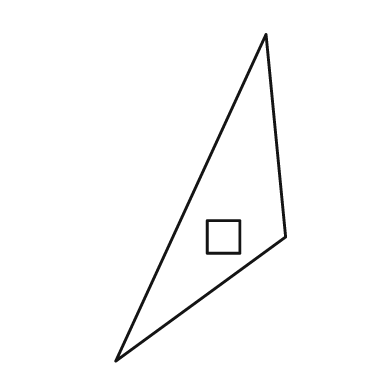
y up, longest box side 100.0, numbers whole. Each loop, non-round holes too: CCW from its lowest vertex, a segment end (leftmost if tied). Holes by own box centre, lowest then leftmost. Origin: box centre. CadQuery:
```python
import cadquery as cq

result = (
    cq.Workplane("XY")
    .moveTo(-26.0, -50.0)
    .lineTo(26.0, -12.0)
    .lineTo(20.0, 50.0)
    .close()
    .moveTo(2.0, -17.0)
    .lineTo(12.0, -17.0)
    .lineTo(12.0, -7.0)
    .lineTo(2.0, -7.0)
    .close()
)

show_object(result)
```